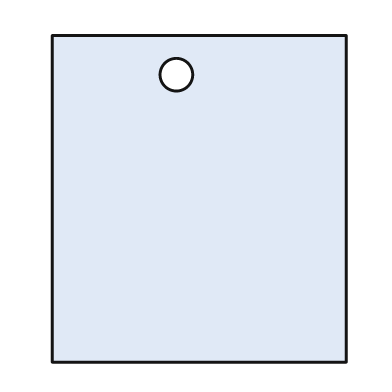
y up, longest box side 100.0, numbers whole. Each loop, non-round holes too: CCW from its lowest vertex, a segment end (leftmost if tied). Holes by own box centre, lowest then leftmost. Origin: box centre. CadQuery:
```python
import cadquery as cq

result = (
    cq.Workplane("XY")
    .moveTo(-45.0, -50.0)
    .lineTo(45.0, -50.0)
    .lineTo(45.0, 50.0)
    .lineTo(-45.0, 50.0)
    .close()
    .moveTo(-7.0, 38.0)
    .circle(5.0)
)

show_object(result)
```